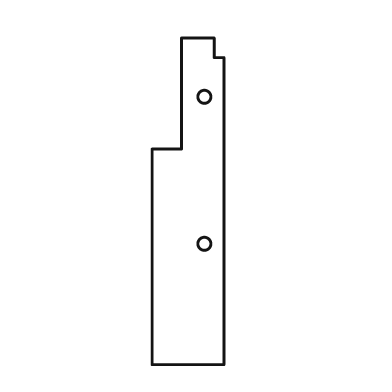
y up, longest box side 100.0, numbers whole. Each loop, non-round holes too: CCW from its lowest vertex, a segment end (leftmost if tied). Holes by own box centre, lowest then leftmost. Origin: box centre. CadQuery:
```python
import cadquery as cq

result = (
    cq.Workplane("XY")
    .moveTo(-11.0, -50.0)
    .lineTo(11.0, -50.0)
    .lineTo(11.0, 44.0)
    .lineTo(8.0, 44.0)
    .lineTo(8.0, 50.0)
    .lineTo(-2.0, 50.0)
    .lineTo(-2.0, 16.0)
    .lineTo(-11.0, 16.0)
    .close()
    .moveTo(5.0, -13.0)
    .circle(2.0)
    .moveTo(5.0, 32.0)
    .circle(2.0)
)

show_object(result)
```